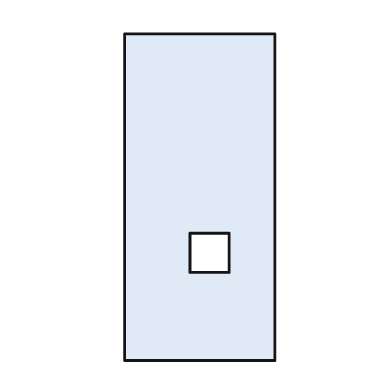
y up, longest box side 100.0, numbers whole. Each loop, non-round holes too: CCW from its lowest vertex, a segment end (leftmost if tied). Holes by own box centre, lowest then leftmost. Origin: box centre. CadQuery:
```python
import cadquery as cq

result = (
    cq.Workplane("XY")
    .moveTo(-23.0, -50.0)
    .lineTo(23.0, -50.0)
    .lineTo(23.0, 50.0)
    .lineTo(-23.0, 50.0)
    .close()
    .moveTo(-3.0, -23.0)
    .lineTo(9.0, -23.0)
    .lineTo(9.0, -11.0)
    .lineTo(-3.0, -11.0)
    .close()
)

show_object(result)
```